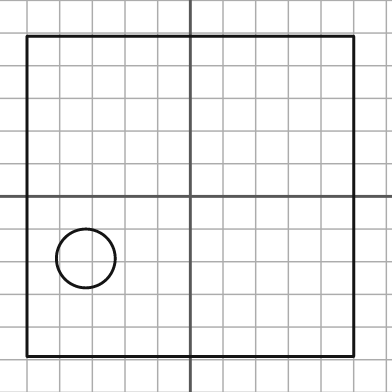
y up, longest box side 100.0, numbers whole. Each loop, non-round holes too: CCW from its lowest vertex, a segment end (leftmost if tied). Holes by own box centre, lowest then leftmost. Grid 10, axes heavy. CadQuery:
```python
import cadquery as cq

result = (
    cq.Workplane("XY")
    .moveTo(-50.0, -49.0)
    .lineTo(50.0, -49.0)
    .lineTo(50.0, 49.0)
    .lineTo(-50.0, 49.0)
    .close()
    .moveTo(-32.0, -19.0)
    .circle(9.0)
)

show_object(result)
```